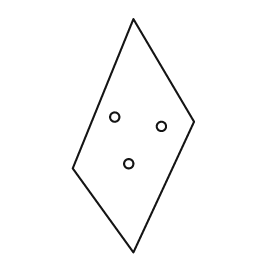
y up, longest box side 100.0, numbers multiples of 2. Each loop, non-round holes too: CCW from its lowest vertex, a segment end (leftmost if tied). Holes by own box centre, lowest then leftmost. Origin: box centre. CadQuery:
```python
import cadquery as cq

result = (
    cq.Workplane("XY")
    .moveTo(0.0, -50.0)
    .lineTo(26.0, 6.0)
    .lineTo(0.0, 50.0)
    .lineTo(-26.0, -14.0)
    .close()
    .moveTo(-2.0, -12.0)
    .circle(2.0)
    .moveTo(12.0, 4.0)
    .circle(2.0)
    .moveTo(-8.0, 8.0)
    .circle(2.0)
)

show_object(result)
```